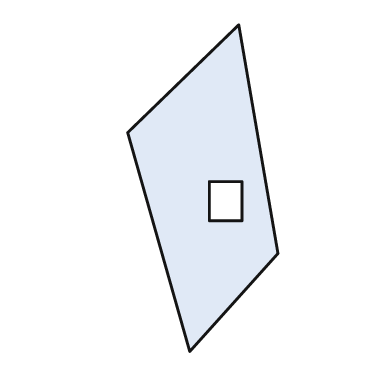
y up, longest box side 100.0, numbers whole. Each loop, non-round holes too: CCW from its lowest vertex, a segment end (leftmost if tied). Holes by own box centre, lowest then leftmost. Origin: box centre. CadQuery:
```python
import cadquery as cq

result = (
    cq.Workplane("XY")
    .moveTo(-4.0, -50.0)
    .lineTo(23.0, -20.0)
    .lineTo(11.0, 50.0)
    .lineTo(-23.0, 17.0)
    .close()
    .moveTo(2.0, -10.0)
    .lineTo(12.0, -10.0)
    .lineTo(12.0, 2.0)
    .lineTo(2.0, 2.0)
    .close()
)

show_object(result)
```